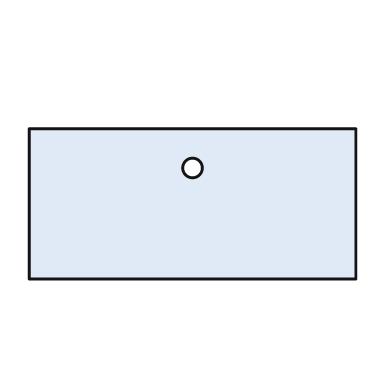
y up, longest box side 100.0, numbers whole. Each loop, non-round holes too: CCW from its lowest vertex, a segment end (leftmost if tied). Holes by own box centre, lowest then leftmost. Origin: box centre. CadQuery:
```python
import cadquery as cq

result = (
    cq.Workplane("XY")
    .moveTo(-50.0, -23.0)
    .lineTo(50.0, -23.0)
    .lineTo(50.0, 23.0)
    .lineTo(-50.0, 23.0)
    .close()
    .moveTo(0.0, 11.0)
    .circle(3.0)
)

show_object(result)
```